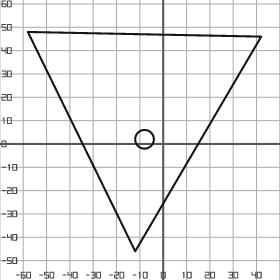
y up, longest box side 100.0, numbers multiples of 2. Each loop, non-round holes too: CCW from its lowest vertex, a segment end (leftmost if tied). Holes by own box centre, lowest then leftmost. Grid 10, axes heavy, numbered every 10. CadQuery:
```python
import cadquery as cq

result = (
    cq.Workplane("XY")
    .moveTo(-12.0, -46.0)
    .lineTo(42.0, 46.0)
    .lineTo(-58.0, 48.0)
    .close()
    .moveTo(-8.0, 2.0)
    .circle(4.0)
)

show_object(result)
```